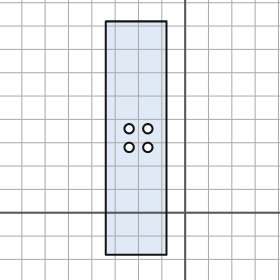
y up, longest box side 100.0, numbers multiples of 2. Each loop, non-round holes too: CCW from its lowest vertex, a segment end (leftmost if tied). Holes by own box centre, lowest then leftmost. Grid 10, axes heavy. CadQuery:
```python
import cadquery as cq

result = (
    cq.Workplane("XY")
    .moveTo(-34.0, -18.0)
    .lineTo(-8.0, -18.0)
    .lineTo(-8.0, 82.0)
    .lineTo(-34.0, 82.0)
    .close()
    .moveTo(-24.0, 28.0)
    .circle(2.0)
    .moveTo(-16.0, 28.0)
    .circle(2.0)
    .moveTo(-24.0, 36.0)
    .circle(2.0)
    .moveTo(-16.0, 36.0)
    .circle(2.0)
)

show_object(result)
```